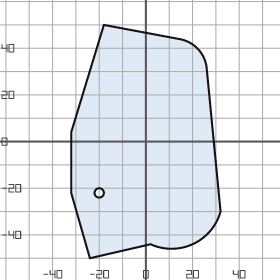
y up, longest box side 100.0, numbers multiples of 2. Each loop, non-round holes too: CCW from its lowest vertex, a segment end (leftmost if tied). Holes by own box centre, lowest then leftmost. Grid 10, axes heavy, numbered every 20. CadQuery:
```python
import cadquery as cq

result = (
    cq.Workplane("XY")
    .moveTo(-24.0, -50.0)
    .lineTo(2.0, -44.0)
    .threePointArc((20.0, -44.0), (32.0, -30.0))
    .lineTo(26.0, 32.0)
    .threePointArc((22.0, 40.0), (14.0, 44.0))
    .lineTo(-18.0, 50.0)
    .lineTo(-32.0, 4.0)
    .lineTo(-32.0, -22.0)
    .close()
    .moveTo(-20.0, -22.0)
    .circle(2.0)
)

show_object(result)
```